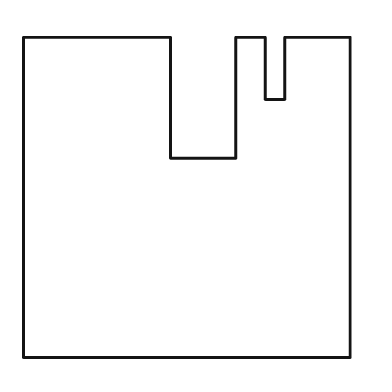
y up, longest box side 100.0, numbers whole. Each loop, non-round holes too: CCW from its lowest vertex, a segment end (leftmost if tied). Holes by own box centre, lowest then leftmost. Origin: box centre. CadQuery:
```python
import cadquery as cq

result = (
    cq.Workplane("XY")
    .moveTo(-50.0, -49.0)
    .lineTo(50.0, -49.0)
    .lineTo(50.0, 49.0)
    .lineTo(30.0, 49.0)
    .lineTo(30.0, 30.0)
    .lineTo(24.0, 30.0)
    .lineTo(24.0, 49.0)
    .lineTo(15.0, 49.0)
    .lineTo(15.0, 12.0)
    .lineTo(-5.0, 12.0)
    .lineTo(-5.0, 49.0)
    .lineTo(-50.0, 49.0)
    .close()
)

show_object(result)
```